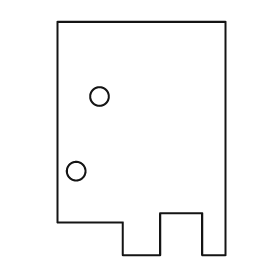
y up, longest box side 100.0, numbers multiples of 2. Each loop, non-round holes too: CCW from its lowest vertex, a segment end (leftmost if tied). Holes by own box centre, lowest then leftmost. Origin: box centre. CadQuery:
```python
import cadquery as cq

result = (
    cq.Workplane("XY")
    .moveTo(-8.0, -50.0)
    .lineTo(8.0, -50.0)
    .lineTo(8.0, -32.0)
    .lineTo(26.0, -32.0)
    .lineTo(26.0, -50.0)
    .lineTo(36.0, -50.0)
    .lineTo(36.0, 50.0)
    .lineTo(-36.0, 50.0)
    .lineTo(-36.0, -36.0)
    .lineTo(-8.0, -36.0)
    .close()
    .moveTo(-28.0, -14.0)
    .circle(4.0)
    .moveTo(-18.0, 18.0)
    .circle(4.0)
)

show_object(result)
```